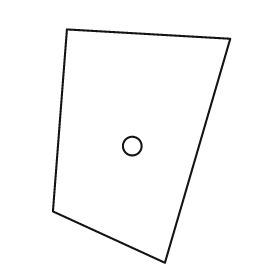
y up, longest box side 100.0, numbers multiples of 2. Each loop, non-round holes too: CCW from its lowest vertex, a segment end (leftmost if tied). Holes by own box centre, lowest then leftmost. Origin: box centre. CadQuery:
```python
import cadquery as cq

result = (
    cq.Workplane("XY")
    .moveTo(10.0, -50.0)
    .lineTo(38.0, 46.0)
    .lineTo(-32.0, 50.0)
    .lineTo(-38.0, -28.0)
    .close()
    .moveTo(-4.0, 0.0)
    .circle(4.0)
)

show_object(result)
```